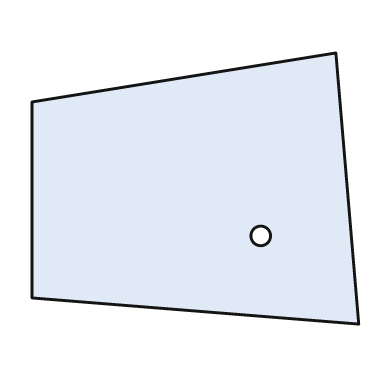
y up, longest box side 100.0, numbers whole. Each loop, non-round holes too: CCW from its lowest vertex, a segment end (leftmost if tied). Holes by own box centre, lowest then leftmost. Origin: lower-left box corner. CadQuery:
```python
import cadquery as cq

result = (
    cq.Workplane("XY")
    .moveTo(100.0, 0.0)
    .lineTo(93.0, 83.0)
    .lineTo(0.0, 68.0)
    .lineTo(0.0, 8.0)
    .close()
    .moveTo(70.0, 27.0)
    .circle(3.0)
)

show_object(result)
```